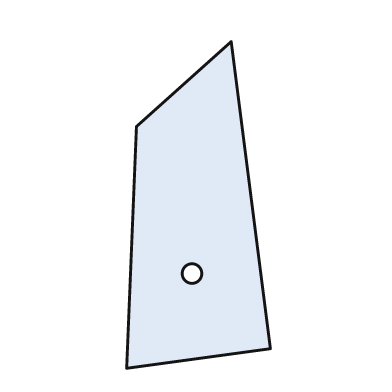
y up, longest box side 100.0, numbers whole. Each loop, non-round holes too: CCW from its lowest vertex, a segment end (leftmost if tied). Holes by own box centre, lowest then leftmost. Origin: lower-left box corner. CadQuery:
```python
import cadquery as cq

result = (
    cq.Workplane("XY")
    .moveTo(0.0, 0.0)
    .lineTo(44.0, 6.0)
    .lineTo(32.0, 100.0)
    .lineTo(3.0, 74.0)
    .close()
    .moveTo(20.0, 29.0)
    .circle(3.0)
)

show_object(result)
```